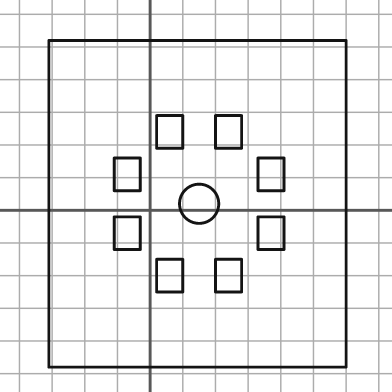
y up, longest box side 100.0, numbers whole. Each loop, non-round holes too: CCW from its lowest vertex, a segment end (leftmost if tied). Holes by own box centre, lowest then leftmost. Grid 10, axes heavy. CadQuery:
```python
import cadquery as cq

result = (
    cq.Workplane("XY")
    .moveTo(-31.0, -48.0)
    .lineTo(60.0, -48.0)
    .lineTo(60.0, 52.0)
    .lineTo(-31.0, 52.0)
    .close()
    .moveTo(2.0, -25.0)
    .lineTo(10.0, -25.0)
    .lineTo(10.0, -15.0)
    .lineTo(2.0, -15.0)
    .close()
    .moveTo(20.0, -25.0)
    .lineTo(28.0, -25.0)
    .lineTo(28.0, -15.0)
    .lineTo(20.0, -15.0)
    .close()
    .moveTo(-11.0, -12.0)
    .lineTo(-3.0, -12.0)
    .lineTo(-3.0, -2.0)
    .lineTo(-11.0, -2.0)
    .close()
    .moveTo(33.0, -12.0)
    .lineTo(41.0, -12.0)
    .lineTo(41.0, -2.0)
    .lineTo(33.0, -2.0)
    .close()
    .moveTo(15.0, 2.0)
    .circle(6.0)
    .moveTo(-11.0, 6.0)
    .lineTo(-3.0, 6.0)
    .lineTo(-3.0, 16.0)
    .lineTo(-11.0, 16.0)
    .close()
    .moveTo(33.0, 6.0)
    .lineTo(41.0, 6.0)
    .lineTo(41.0, 16.0)
    .lineTo(33.0, 16.0)
    .close()
    .moveTo(2.0, 19.0)
    .lineTo(10.0, 19.0)
    .lineTo(10.0, 29.0)
    .lineTo(2.0, 29.0)
    .close()
    .moveTo(20.0, 19.0)
    .lineTo(28.0, 19.0)
    .lineTo(28.0, 29.0)
    .lineTo(20.0, 29.0)
    .close()
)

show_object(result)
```